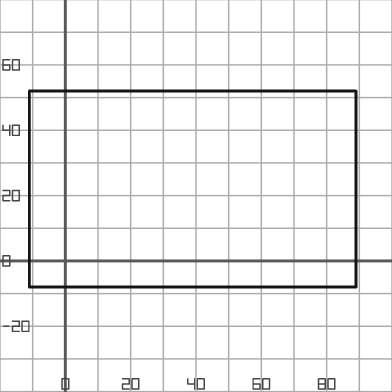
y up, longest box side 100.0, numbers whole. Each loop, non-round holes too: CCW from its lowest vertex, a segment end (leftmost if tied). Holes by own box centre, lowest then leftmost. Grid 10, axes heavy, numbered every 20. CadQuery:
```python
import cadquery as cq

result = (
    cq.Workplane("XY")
    .moveTo(-11.0, -8.0)
    .lineTo(89.0, -8.0)
    .lineTo(89.0, 52.0)
    .lineTo(-11.0, 52.0)
    .close()
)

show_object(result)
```